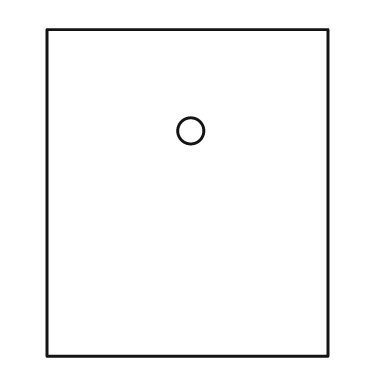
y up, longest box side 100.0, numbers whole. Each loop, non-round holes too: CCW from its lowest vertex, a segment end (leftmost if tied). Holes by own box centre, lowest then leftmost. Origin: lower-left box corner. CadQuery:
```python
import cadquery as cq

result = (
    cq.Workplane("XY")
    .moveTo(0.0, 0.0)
    .lineTo(86.0, 0.0)
    .lineTo(86.0, 100.0)
    .lineTo(0.0, 100.0)
    .close()
    .moveTo(44.0, 69.0)
    .circle(4.0)
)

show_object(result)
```